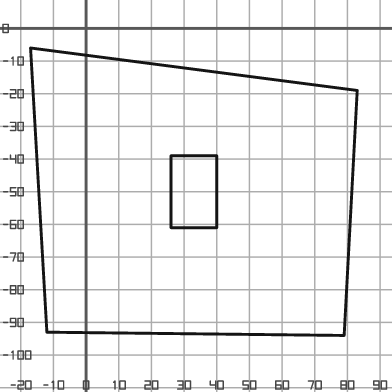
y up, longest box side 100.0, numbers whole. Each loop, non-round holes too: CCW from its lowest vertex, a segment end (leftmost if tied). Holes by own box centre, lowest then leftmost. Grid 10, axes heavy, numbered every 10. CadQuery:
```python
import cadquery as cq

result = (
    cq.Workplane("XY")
    .moveTo(79.0, -94.0)
    .lineTo(83.0, -19.0)
    .lineTo(-17.0, -6.0)
    .lineTo(-12.0, -93.0)
    .close()
    .moveTo(26.0, -61.0)
    .lineTo(40.0, -61.0)
    .lineTo(40.0, -39.0)
    .lineTo(26.0, -39.0)
    .close()
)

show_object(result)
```